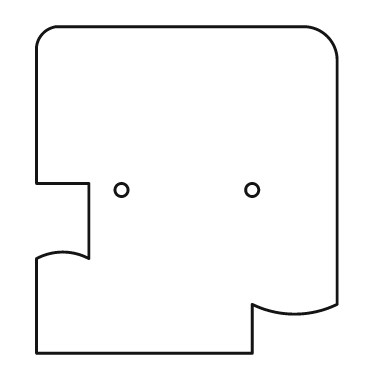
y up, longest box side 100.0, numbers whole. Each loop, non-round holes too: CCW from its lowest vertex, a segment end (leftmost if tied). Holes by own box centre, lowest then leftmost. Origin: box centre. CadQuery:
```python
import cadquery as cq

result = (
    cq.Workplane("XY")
    .moveTo(-46.0, -50.0)
    .lineTo(20.0, -50.0)
    .lineTo(20.0, -35.0)
    .threePointArc((33.0, -38.0), (46.0, -35.0))
    .lineTo(46.0, 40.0)
    .threePointArc((43.0, 47.0), (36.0, 50.0))
    .lineTo(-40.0, 50.0)
    .threePointArc((-44.0, 48.0), (-46.0, 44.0))
    .lineTo(-46.0, 2.0)
    .lineTo(-30.0, 2.0)
    .lineTo(-30.0, -21.0)
    .threePointArc((-38.0, -19.0), (-46.0, -21.0))
    .close()
    .moveTo(-20.0, 0.0)
    .circle(2.0)
    .moveTo(20.0, 0.0)
    .circle(2.0)
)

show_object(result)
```